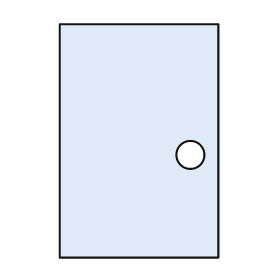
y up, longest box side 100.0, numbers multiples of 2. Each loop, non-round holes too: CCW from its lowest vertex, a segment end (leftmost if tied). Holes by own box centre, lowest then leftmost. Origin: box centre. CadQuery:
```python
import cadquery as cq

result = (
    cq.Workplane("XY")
    .moveTo(-34.0, -50.0)
    .lineTo(34.0, -50.0)
    .lineTo(34.0, 50.0)
    .lineTo(-34.0, 50.0)
    .close()
    .moveTo(22.0, -6.0)
    .circle(6.0)
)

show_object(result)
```